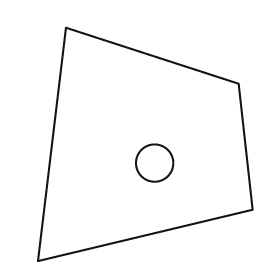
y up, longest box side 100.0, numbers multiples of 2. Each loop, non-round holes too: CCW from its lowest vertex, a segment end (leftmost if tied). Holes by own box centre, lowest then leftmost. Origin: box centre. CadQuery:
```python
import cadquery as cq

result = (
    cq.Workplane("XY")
    .moveTo(-46.0, -50.0)
    .lineTo(46.0, -28.0)
    .lineTo(40.0, 26.0)
    .lineTo(-34.0, 50.0)
    .close()
    .moveTo(4.0, -8.0)
    .circle(8.0)
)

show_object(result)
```